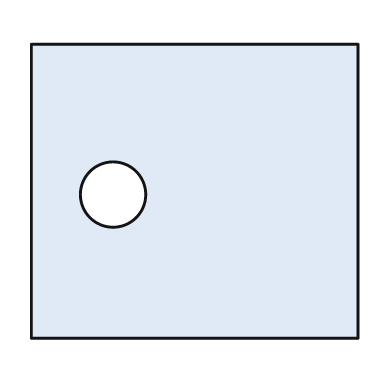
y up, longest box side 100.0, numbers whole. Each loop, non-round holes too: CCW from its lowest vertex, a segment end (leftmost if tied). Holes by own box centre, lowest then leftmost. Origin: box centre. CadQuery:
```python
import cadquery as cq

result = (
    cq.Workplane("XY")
    .moveTo(-50.0, -45.0)
    .lineTo(50.0, -45.0)
    .lineTo(50.0, 45.0)
    .lineTo(-50.0, 45.0)
    .close()
    .moveTo(-25.0, -1.0)
    .circle(10.0)
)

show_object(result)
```